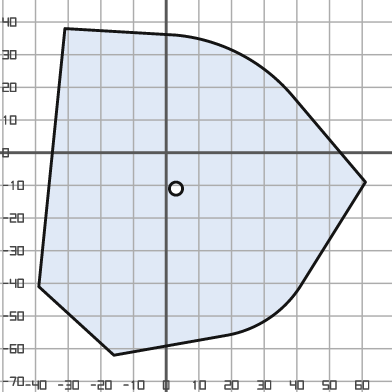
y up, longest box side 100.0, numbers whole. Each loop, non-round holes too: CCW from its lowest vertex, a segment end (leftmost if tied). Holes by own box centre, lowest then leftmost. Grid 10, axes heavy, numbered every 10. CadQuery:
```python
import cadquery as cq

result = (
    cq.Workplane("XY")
    .moveTo(-16.0, -62.0)
    .lineTo(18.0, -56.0)
    .threePointArc((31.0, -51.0), (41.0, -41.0))
    .lineTo(61.0, -9.0)
    .lineTo(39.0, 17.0)
    .threePointArc((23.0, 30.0), (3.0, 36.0))
    .lineTo(-31.0, 38.0)
    .lineTo(-39.0, -41.0)
    .close()
    .moveTo(3.0, -11.0)
    .circle(2.0)
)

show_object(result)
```